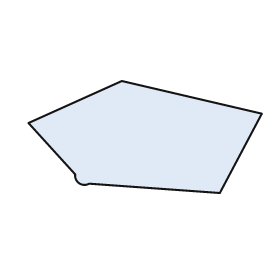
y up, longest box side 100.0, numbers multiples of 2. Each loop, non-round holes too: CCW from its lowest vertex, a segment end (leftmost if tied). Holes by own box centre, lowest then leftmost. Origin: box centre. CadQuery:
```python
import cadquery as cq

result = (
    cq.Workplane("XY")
    .moveTo(32.0, -24.0)
    .lineTo(50.0, 10.0)
    .lineTo(-10.0, 24.0)
    .lineTo(-50.0, 6.0)
    .lineTo(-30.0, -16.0)
    .threePointArc((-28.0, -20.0), (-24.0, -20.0))
    .close()
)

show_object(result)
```